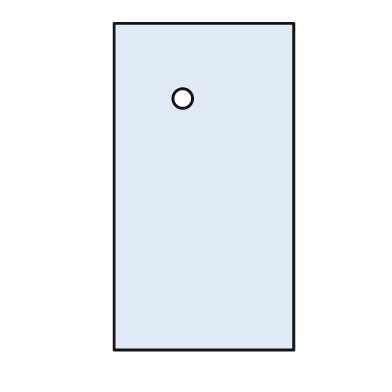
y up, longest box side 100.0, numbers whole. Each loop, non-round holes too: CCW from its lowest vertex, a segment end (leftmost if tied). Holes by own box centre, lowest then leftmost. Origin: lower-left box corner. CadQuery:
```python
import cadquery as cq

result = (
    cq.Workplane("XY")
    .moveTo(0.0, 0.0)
    .lineTo(55.0, 0.0)
    .lineTo(55.0, 100.0)
    .lineTo(0.0, 100.0)
    .close()
    .moveTo(21.0, 77.0)
    .circle(3.0)
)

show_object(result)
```